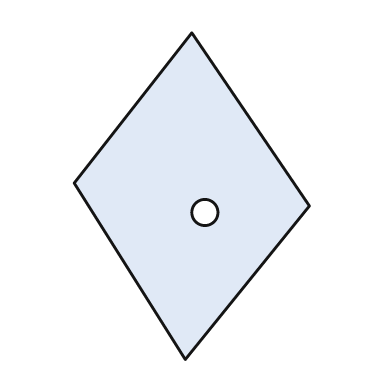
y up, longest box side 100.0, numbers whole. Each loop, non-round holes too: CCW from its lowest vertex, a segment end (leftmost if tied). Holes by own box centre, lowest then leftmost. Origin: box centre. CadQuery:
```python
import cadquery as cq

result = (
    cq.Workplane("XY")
    .moveTo(-2.0, -50.0)
    .lineTo(36.0, -3.0)
    .lineTo(0.0, 50.0)
    .lineTo(-36.0, 4.0)
    .close()
    .moveTo(4.0, -5.0)
    .circle(4.0)
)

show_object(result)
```